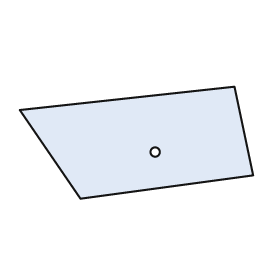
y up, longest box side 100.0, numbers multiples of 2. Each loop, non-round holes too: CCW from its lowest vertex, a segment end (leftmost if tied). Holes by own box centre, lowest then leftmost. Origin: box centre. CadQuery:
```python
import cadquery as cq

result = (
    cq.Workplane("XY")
    .moveTo(-24.0, -24.0)
    .lineTo(50.0, -14.0)
    .lineTo(42.0, 24.0)
    .lineTo(-50.0, 14.0)
    .close()
    .moveTo(8.0, -4.0)
    .circle(2.0)
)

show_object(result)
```